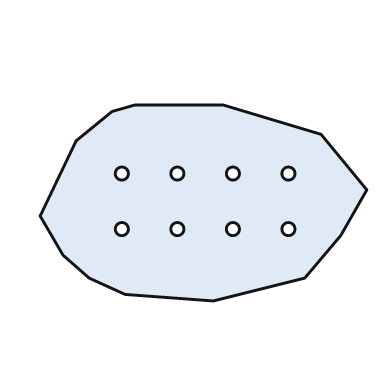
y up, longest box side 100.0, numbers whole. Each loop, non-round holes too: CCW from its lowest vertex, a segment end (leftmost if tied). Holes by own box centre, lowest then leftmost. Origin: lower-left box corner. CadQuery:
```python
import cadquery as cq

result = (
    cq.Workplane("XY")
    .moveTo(53.0, 0.0)
    .lineTo(81.0, 7.0)
    .lineTo(92.0, 20.0)
    .lineTo(100.0, 34.0)
    .lineTo(86.0, 51.0)
    .lineTo(56.0, 60.0)
    .lineTo(29.0, 60.0)
    .lineTo(22.0, 58.0)
    .lineTo(11.0, 49.0)
    .lineTo(0.0, 26.0)
    .lineTo(7.0, 14.0)
    .lineTo(15.0, 7.0)
    .lineTo(26.0, 2.0)
    .close()
    .moveTo(25.0, 22.0)
    .circle(2.0)
    .moveTo(42.0, 22.0)
    .circle(2.0)
    .moveTo(59.0, 22.0)
    .circle(2.0)
    .moveTo(76.0, 22.0)
    .circle(2.0)
    .moveTo(25.0, 39.0)
    .circle(2.0)
    .moveTo(42.0, 39.0)
    .circle(2.0)
    .moveTo(59.0, 39.0)
    .circle(2.0)
    .moveTo(76.0, 39.0)
    .circle(2.0)
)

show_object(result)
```